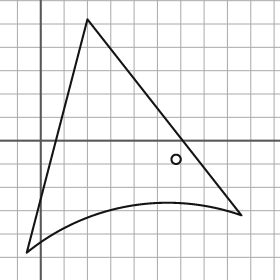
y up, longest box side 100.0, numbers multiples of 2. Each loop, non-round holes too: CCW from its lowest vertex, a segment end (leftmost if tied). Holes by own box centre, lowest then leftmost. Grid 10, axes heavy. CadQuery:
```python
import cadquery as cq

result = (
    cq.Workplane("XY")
    .moveTo(-6.0, -48.0)
    .threePointArc((38.0, -28.0), (86.0, -32.0))
    .lineTo(20.0, 52.0)
    .close()
    .moveTo(58.0, -8.0)
    .circle(2.0)
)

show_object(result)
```